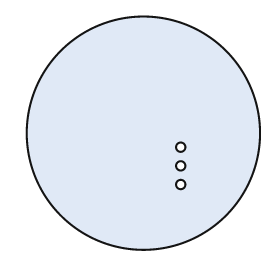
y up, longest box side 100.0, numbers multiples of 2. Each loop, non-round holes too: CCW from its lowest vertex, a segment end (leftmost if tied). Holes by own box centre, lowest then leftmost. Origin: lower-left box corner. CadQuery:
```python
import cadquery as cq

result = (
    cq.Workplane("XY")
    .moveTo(50.0, 50.0)
    .circle(50.0)
    .moveTo(66.0, 28.0)
    .circle(2.0)
    .moveTo(66.0, 36.0)
    .circle(2.0)
    .moveTo(66.0, 44.0)
    .circle(2.0)
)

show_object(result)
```